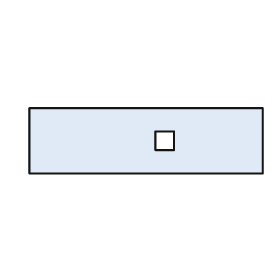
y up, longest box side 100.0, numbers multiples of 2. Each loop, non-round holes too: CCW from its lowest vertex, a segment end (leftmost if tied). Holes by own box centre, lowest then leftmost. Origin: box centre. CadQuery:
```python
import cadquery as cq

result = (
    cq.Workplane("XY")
    .moveTo(-50.0, -14.0)
    .lineTo(50.0, -14.0)
    .lineTo(50.0, 14.0)
    .lineTo(-50.0, 14.0)
    .close()
    .moveTo(4.0, -4.0)
    .lineTo(12.0, -4.0)
    .lineTo(12.0, 4.0)
    .lineTo(4.0, 4.0)
    .close()
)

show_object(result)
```